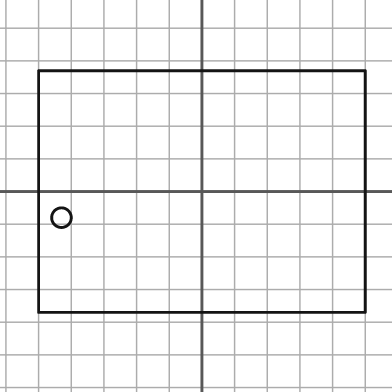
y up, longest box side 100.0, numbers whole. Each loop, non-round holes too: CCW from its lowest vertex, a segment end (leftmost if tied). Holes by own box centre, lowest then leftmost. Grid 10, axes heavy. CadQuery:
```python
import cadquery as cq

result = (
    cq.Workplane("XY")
    .moveTo(-50.0, -37.0)
    .lineTo(50.0, -37.0)
    .lineTo(50.0, 37.0)
    .lineTo(-50.0, 37.0)
    .close()
    .moveTo(-43.0, -8.0)
    .circle(3.0)
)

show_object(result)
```